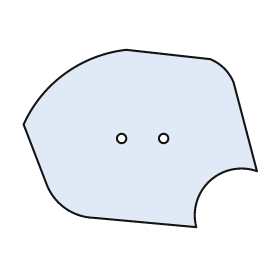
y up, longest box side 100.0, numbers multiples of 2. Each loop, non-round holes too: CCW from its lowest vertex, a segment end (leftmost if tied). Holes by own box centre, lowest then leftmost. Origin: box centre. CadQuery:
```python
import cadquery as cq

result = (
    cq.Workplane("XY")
    .moveTo(24.0, -38.0)
    .threePointArc((30.0, -18.0), (50.0, -14.0))
    .lineTo(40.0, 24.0)
    .threePointArc((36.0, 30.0), (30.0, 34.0))
    .lineTo(-6.0, 38.0)
    .threePointArc((-32.0, 28.0), (-50.0, 6.0))
    .lineTo(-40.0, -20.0)
    .threePointArc((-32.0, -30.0), (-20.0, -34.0))
    .close()
    .moveTo(-8.0, 0.0)
    .circle(2.0)
    .moveTo(10.0, 0.0)
    .circle(2.0)
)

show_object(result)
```